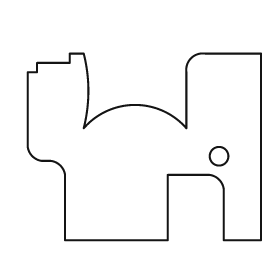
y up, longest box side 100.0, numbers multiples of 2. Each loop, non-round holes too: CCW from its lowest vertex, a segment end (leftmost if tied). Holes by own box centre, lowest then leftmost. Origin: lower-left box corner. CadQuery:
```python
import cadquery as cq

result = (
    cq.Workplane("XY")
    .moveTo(16.0, 0.0)
    .lineTo(60.0, 0.0)
    .lineTo(60.0, 28.0)
    .lineTo(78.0, 28.0)
    .threePointArc((82.0, 26.0), (84.0, 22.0))
    .lineTo(84.0, 0.0)
    .lineTo(100.0, 0.0)
    .lineTo(100.0, 80.0)
    .lineTo(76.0, 80.0)
    .threePointArc((70.0, 78.0), (68.0, 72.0))
    .lineTo(68.0, 48.0)
    .threePointArc((46.0, 58.0), (24.0, 48.0))
    .threePointArc((26.0, 64.0), (24.0, 80.0))
    .lineTo(18.0, 80.0)
    .lineTo(18.0, 76.0)
    .lineTo(4.0, 76.0)
    .lineTo(4.0, 72.0)
    .lineTo(0.0, 72.0)
    .lineTo(0.0, 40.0)
    .threePointArc((2.0, 36.0), (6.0, 34.0))
    .lineTo(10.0, 34.0)
    .threePointArc((14.0, 32.0), (16.0, 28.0))
    .close()
    .moveTo(82.0, 36.0)
    .circle(4.0)
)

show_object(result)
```